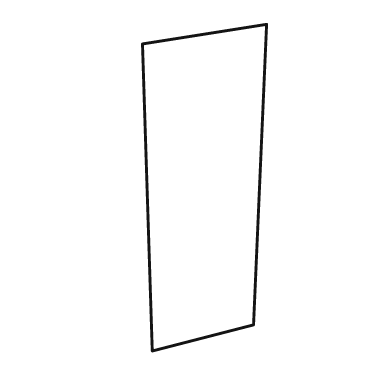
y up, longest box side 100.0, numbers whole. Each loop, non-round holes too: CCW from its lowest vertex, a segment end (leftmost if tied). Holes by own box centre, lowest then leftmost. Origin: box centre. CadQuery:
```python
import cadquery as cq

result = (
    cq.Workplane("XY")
    .moveTo(-16.0, -50.0)
    .lineTo(15.0, -42.0)
    .lineTo(19.0, 50.0)
    .lineTo(-19.0, 44.0)
    .close()
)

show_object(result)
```